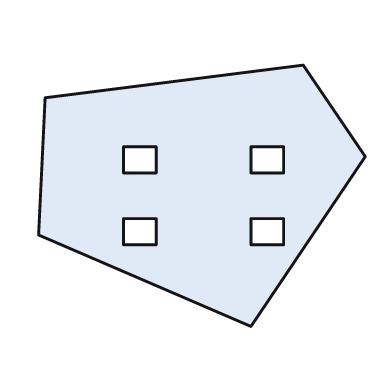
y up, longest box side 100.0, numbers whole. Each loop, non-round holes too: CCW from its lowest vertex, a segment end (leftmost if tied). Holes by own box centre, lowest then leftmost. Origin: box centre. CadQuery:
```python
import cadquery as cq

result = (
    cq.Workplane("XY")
    .moveTo(15.0, -40.0)
    .lineTo(50.0, 12.0)
    .lineTo(31.0, 40.0)
    .lineTo(-48.0, 30.0)
    .lineTo(-50.0, -12.0)
    .close()
    .moveTo(-24.0, -15.0)
    .lineTo(-14.0, -15.0)
    .lineTo(-14.0, -7.0)
    .lineTo(-24.0, -7.0)
    .close()
    .moveTo(15.0, -15.0)
    .lineTo(25.0, -15.0)
    .lineTo(25.0, -7.0)
    .lineTo(15.0, -7.0)
    .close()
    .moveTo(-24.0, 7.0)
    .lineTo(-14.0, 7.0)
    .lineTo(-14.0, 15.0)
    .lineTo(-24.0, 15.0)
    .close()
    .moveTo(15.0, 7.0)
    .lineTo(25.0, 7.0)
    .lineTo(25.0, 15.0)
    .lineTo(15.0, 15.0)
    .close()
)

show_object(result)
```